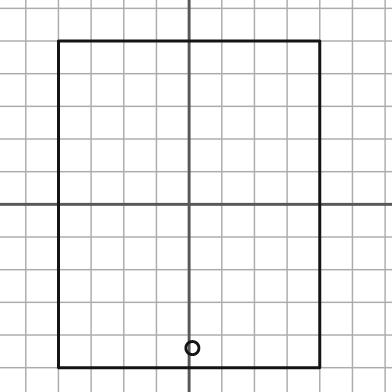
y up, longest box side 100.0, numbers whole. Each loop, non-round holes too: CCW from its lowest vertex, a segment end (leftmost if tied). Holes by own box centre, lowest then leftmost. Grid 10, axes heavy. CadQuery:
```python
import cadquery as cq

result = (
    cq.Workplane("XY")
    .moveTo(-40.0, -50.0)
    .lineTo(40.0, -50.0)
    .lineTo(40.0, 50.0)
    .lineTo(-40.0, 50.0)
    .close()
    .moveTo(1.0, -44.0)
    .circle(2.0)
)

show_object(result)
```